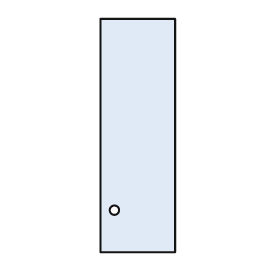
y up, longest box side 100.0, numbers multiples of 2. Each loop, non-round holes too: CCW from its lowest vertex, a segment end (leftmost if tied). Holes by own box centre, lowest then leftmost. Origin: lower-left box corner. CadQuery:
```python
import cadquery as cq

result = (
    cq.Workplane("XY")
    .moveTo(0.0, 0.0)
    .lineTo(32.0, 0.0)
    .lineTo(32.0, 100.0)
    .lineTo(0.0, 100.0)
    .close()
    .moveTo(6.0, 18.0)
    .circle(2.0)
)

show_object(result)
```